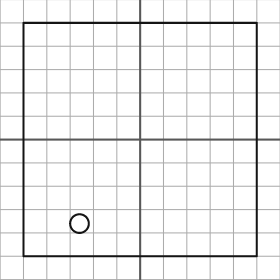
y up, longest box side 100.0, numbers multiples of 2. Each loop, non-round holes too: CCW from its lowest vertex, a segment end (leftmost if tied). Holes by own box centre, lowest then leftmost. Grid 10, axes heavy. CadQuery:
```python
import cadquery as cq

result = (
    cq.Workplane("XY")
    .moveTo(-50.0, -50.0)
    .lineTo(50.0, -50.0)
    .lineTo(50.0, 50.0)
    .lineTo(-50.0, 50.0)
    .close()
    .moveTo(-26.0, -36.0)
    .circle(4.0)
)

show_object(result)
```